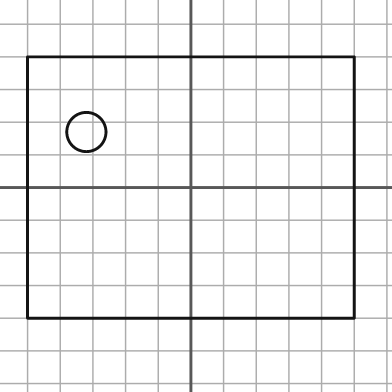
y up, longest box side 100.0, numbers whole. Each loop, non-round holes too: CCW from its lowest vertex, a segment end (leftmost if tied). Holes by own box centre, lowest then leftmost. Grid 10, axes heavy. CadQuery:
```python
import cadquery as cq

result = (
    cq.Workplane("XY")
    .moveTo(-50.0, -40.0)
    .lineTo(50.0, -40.0)
    .lineTo(50.0, 40.0)
    .lineTo(-50.0, 40.0)
    .close()
    .moveTo(-32.0, 17.0)
    .circle(6.0)
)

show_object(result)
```